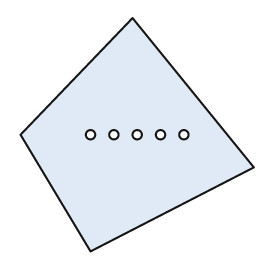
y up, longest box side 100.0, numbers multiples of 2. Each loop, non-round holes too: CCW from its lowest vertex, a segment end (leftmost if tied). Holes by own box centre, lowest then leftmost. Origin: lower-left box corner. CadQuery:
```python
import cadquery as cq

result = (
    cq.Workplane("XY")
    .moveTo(30.0, 0.0)
    .lineTo(100.0, 36.0)
    .lineTo(48.0, 100.0)
    .lineTo(0.0, 50.0)
    .close()
    .moveTo(30.0, 50.0)
    .circle(2.0)
    .moveTo(40.0, 50.0)
    .circle(2.0)
    .moveTo(50.0, 50.0)
    .circle(2.0)
    .moveTo(60.0, 50.0)
    .circle(2.0)
    .moveTo(70.0, 50.0)
    .circle(2.0)
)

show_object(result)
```